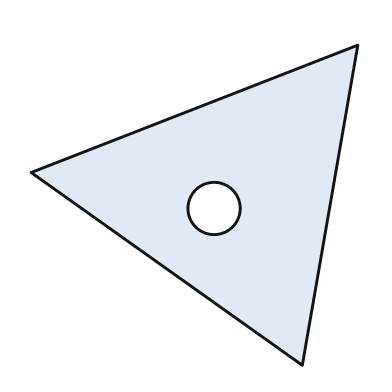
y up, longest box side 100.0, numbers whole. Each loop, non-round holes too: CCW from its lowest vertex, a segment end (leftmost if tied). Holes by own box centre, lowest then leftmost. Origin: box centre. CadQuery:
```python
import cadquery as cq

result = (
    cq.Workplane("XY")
    .moveTo(33.0, -49.0)
    .lineTo(50.0, 49.0)
    .lineTo(-50.0, 10.0)
    .close()
    .moveTo(6.0, -1.0)
    .circle(8.0)
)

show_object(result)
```